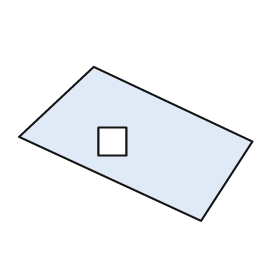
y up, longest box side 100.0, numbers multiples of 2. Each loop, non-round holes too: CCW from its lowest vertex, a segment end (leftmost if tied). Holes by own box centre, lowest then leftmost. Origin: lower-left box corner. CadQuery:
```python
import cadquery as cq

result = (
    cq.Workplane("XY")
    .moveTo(78.0, 0.0)
    .lineTo(100.0, 34.0)
    .lineTo(32.0, 66.0)
    .lineTo(0.0, 36.0)
    .close()
    .moveTo(34.0, 28.0)
    .lineTo(46.0, 28.0)
    .lineTo(46.0, 40.0)
    .lineTo(34.0, 40.0)
    .close()
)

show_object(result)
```